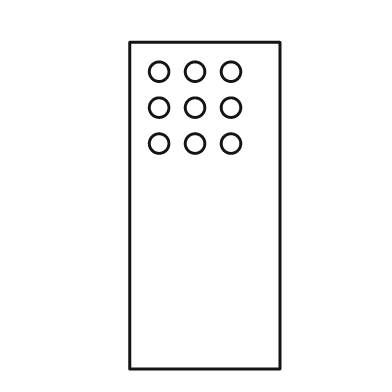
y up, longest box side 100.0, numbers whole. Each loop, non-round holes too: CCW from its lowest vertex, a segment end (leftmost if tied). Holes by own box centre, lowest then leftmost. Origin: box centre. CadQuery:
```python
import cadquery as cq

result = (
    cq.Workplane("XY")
    .moveTo(-23.0, -50.0)
    .lineTo(23.0, -50.0)
    .lineTo(23.0, 50.0)
    .lineTo(-23.0, 50.0)
    .close()
    .moveTo(-14.0, 19.0)
    .circle(3.0)
    .moveTo(-3.0, 19.0)
    .circle(3.0)
    .moveTo(8.0, 19.0)
    .circle(3.0)
    .moveTo(-14.0, 30.0)
    .circle(3.0)
    .moveTo(-3.0, 30.0)
    .circle(3.0)
    .moveTo(8.0, 30.0)
    .circle(3.0)
    .moveTo(-14.0, 41.0)
    .circle(3.0)
    .moveTo(-3.0, 41.0)
    .circle(3.0)
    .moveTo(8.0, 41.0)
    .circle(3.0)
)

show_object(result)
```